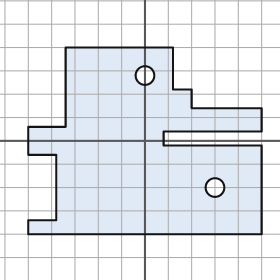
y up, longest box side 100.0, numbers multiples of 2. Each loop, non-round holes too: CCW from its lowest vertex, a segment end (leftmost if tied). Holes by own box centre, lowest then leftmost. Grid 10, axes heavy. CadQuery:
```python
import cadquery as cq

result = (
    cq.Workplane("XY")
    .moveTo(-50.0, -40.0)
    .lineTo(50.0, -40.0)
    .lineTo(50.0, -2.0)
    .lineTo(8.0, -2.0)
    .lineTo(8.0, 4.0)
    .lineTo(50.0, 4.0)
    .lineTo(50.0, 14.0)
    .lineTo(20.0, 14.0)
    .lineTo(20.0, 22.0)
    .lineTo(12.0, 22.0)
    .lineTo(12.0, 40.0)
    .lineTo(-34.0, 40.0)
    .lineTo(-34.0, 6.0)
    .lineTo(-50.0, 6.0)
    .lineTo(-50.0, -6.0)
    .lineTo(-38.0, -6.0)
    .lineTo(-38.0, -34.0)
    .lineTo(-50.0, -34.0)
    .close()
    .moveTo(30.0, -20.0)
    .circle(4.0)
    .moveTo(0.0, 28.0)
    .circle(4.0)
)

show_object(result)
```